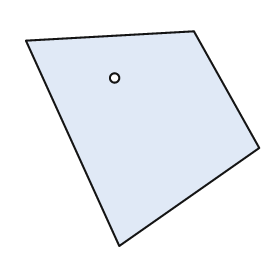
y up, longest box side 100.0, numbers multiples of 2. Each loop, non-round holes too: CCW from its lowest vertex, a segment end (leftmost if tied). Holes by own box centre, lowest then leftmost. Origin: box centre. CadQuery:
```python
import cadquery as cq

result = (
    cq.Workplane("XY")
    .moveTo(-10.0, -46.0)
    .lineTo(50.0, -4.0)
    .lineTo(22.0, 46.0)
    .lineTo(-50.0, 42.0)
    .close()
    .moveTo(-12.0, 26.0)
    .circle(2.0)
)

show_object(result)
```